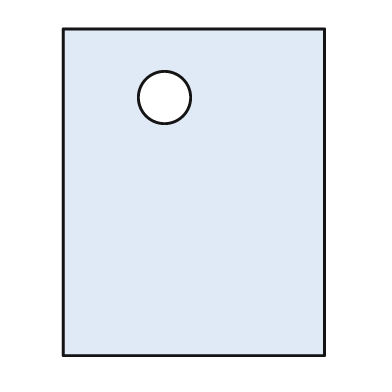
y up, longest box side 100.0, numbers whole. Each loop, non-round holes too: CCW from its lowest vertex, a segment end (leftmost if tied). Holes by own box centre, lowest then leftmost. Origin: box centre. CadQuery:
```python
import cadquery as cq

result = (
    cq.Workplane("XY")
    .moveTo(-40.0, -50.0)
    .lineTo(40.0, -50.0)
    .lineTo(40.0, 50.0)
    .lineTo(-40.0, 50.0)
    .close()
    .moveTo(-9.0, 29.0)
    .circle(8.0)
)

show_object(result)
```